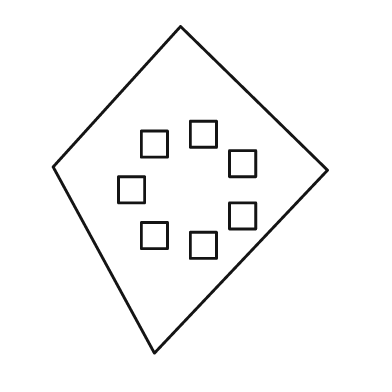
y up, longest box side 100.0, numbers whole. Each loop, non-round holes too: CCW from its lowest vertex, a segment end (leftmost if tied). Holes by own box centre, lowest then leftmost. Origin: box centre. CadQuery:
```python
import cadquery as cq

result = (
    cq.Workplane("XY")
    .moveTo(-11.0, -50.0)
    .lineTo(42.0, 6.0)
    .lineTo(-3.0, 50.0)
    .lineTo(-42.0, 7.0)
    .close()
    .moveTo(0.0, -21.0)
    .lineTo(8.0, -21.0)
    .lineTo(8.0, -13.0)
    .lineTo(0.0, -13.0)
    .close()
    .moveTo(-15.0, -18.0)
    .lineTo(-7.0, -18.0)
    .lineTo(-7.0, -10.0)
    .lineTo(-15.0, -10.0)
    .close()
    .moveTo(12.0, -12.0)
    .lineTo(20.0, -12.0)
    .lineTo(20.0, -4.0)
    .lineTo(12.0, -4.0)
    .close()
    .moveTo(-22.0, -4.0)
    .lineTo(-14.0, -4.0)
    .lineTo(-14.0, 4.0)
    .lineTo(-22.0, 4.0)
    .close()
    .moveTo(12.0, 4.0)
    .lineTo(20.0, 4.0)
    .lineTo(20.0, 12.0)
    .lineTo(12.0, 12.0)
    .close()
    .moveTo(-15.0, 10.0)
    .lineTo(-7.0, 10.0)
    .lineTo(-7.0, 18.0)
    .lineTo(-15.0, 18.0)
    .close()
    .moveTo(0.0, 13.0)
    .lineTo(8.0, 13.0)
    .lineTo(8.0, 21.0)
    .lineTo(0.0, 21.0)
    .close()
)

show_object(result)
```